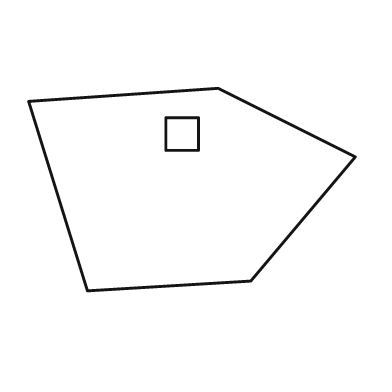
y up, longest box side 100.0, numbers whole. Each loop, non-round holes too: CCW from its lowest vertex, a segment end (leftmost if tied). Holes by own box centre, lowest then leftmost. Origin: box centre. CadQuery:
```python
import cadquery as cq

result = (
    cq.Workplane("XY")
    .moveTo(-32.0, -31.0)
    .lineTo(18.0, -28.0)
    .lineTo(50.0, 10.0)
    .lineTo(8.0, 31.0)
    .lineTo(-50.0, 27.0)
    .close()
    .moveTo(-8.0, 12.0)
    .lineTo(2.0, 12.0)
    .lineTo(2.0, 22.0)
    .lineTo(-8.0, 22.0)
    .close()
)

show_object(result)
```